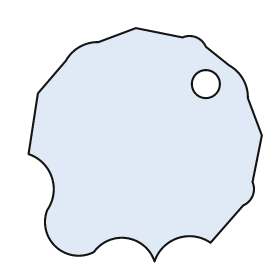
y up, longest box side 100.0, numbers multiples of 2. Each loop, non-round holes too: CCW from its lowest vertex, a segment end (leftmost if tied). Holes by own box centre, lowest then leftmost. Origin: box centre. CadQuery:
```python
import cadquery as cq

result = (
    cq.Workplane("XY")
    .moveTo(4.0, -50.0)
    .threePointArc((14.0, -40.0), (28.0, -42.0))
    .lineTo(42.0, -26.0)
    .threePointArc((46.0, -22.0), (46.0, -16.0))
    .lineTo(50.0, 4.0)
    .lineTo(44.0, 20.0)
    .threePointArc((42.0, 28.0), (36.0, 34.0))
    .lineTo(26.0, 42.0)
    .threePointArc((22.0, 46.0), (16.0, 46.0))
    .lineTo(-4.0, 50.0)
    .lineTo(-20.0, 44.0)
    .threePointArc((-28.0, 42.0), (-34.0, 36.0))
    .lineTo(-46.0, 22.0)
    .lineTo(-50.0, -4.0)
    .threePointArc((-40.0, -14.0), (-42.0, -28.0))
    .threePointArc((-38.0, -44.0), (-22.0, -46.0))
    .threePointArc((-8.0, -40.0), (4.0, -50.0))
    .close()
    .moveTo(26.0, 26.0)
    .circle(6.0)
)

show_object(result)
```